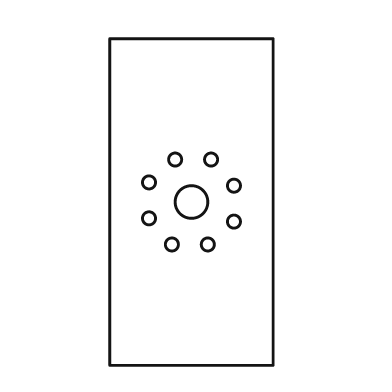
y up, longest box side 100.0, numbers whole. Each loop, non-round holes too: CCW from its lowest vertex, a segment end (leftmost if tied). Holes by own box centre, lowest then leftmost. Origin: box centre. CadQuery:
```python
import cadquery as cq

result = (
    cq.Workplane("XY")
    .moveTo(-25.0, -50.0)
    .lineTo(25.0, -50.0)
    .lineTo(25.0, 50.0)
    .lineTo(-25.0, 50.0)
    .close()
    .moveTo(-6.0, -13.0)
    .circle(2.0)
    .moveTo(5.0, -13.0)
    .circle(2.0)
    .moveTo(13.0, -6.0)
    .circle(2.0)
    .moveTo(-13.0, -5.0)
    .circle(2.0)
    .moveTo(0.0, 0.0)
    .circle(5.0)
    .moveTo(13.0, 5.0)
    .circle(2.0)
    .moveTo(-13.0, 6.0)
    .circle(2.0)
    .moveTo(-5.0, 13.0)
    .circle(2.0)
    .moveTo(6.0, 13.0)
    .circle(2.0)
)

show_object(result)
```